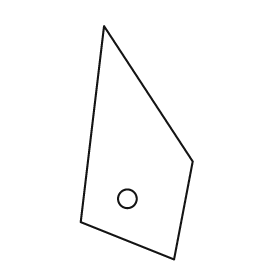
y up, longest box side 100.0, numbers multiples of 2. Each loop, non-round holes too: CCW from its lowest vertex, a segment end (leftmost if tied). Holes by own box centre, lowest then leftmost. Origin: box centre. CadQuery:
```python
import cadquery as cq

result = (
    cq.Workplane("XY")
    .moveTo(16.0, -50.0)
    .lineTo(24.0, -8.0)
    .lineTo(-14.0, 50.0)
    .lineTo(-24.0, -34.0)
    .close()
    .moveTo(-4.0, -24.0)
    .circle(4.0)
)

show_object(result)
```